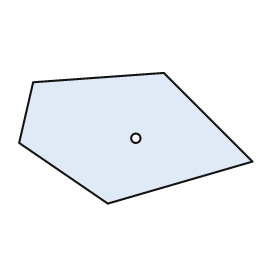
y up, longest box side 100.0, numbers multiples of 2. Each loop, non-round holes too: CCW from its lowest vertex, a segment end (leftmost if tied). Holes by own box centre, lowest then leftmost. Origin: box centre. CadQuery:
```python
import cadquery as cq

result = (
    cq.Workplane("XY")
    .moveTo(-12.0, -28.0)
    .lineTo(50.0, -10.0)
    .lineTo(12.0, 28.0)
    .lineTo(-44.0, 24.0)
    .lineTo(-50.0, -2.0)
    .close()
    .moveTo(0.0, 0.0)
    .circle(2.0)
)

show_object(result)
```